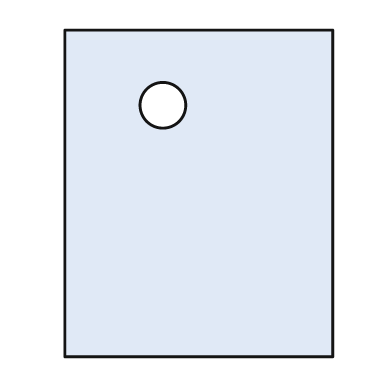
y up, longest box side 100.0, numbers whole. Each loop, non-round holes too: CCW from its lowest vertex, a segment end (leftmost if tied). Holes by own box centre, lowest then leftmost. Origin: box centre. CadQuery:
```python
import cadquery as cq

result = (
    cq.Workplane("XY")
    .moveTo(-41.0, -50.0)
    .lineTo(41.0, -50.0)
    .lineTo(41.0, 50.0)
    .lineTo(-41.0, 50.0)
    .close()
    .moveTo(-11.0, 27.0)
    .circle(7.0)
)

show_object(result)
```